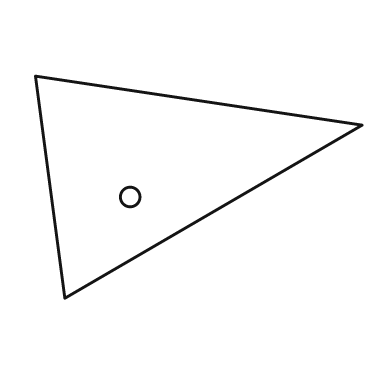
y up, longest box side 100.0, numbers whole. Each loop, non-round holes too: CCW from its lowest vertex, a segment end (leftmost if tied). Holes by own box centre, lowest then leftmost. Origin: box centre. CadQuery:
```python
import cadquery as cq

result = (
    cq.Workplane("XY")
    .moveTo(-41.0, -34.0)
    .lineTo(50.0, 19.0)
    .lineTo(-50.0, 34.0)
    .close()
    .moveTo(-21.0, -3.0)
    .circle(3.0)
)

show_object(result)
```